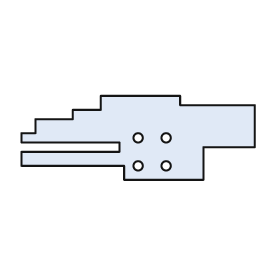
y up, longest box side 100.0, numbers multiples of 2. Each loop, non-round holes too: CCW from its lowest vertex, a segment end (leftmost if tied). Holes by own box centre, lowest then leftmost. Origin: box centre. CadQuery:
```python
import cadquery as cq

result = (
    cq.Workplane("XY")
    .moveTo(-6.0, -18.0)
    .lineTo(28.0, -18.0)
    .lineTo(28.0, -4.0)
    .lineTo(50.0, -4.0)
    .lineTo(50.0, 14.0)
    .lineTo(18.0, 14.0)
    .lineTo(18.0, 18.0)
    .lineTo(-16.0, 18.0)
    .lineTo(-16.0, 12.0)
    .lineTo(-28.0, 12.0)
    .lineTo(-28.0, 8.0)
    .lineTo(-44.0, 8.0)
    .lineTo(-44.0, 2.0)
    .lineTo(-50.0, 2.0)
    .lineTo(-50.0, -2.0)
    .lineTo(-8.0, -2.0)
    .lineTo(-8.0, -6.0)
    .lineTo(-50.0, -6.0)
    .lineTo(-50.0, -12.0)
    .lineTo(-6.0, -12.0)
    .close()
    .moveTo(0.0, -12.0)
    .circle(2.0)
    .moveTo(12.0, -12.0)
    .circle(2.0)
    .moveTo(0.0, 0.0)
    .circle(2.0)
    .moveTo(12.0, 0.0)
    .circle(2.0)
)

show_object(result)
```